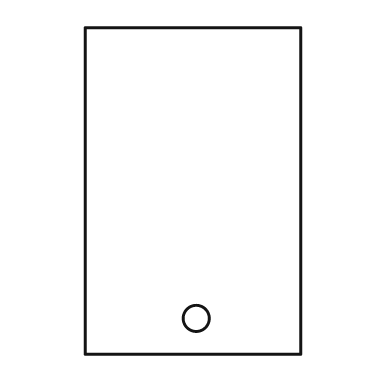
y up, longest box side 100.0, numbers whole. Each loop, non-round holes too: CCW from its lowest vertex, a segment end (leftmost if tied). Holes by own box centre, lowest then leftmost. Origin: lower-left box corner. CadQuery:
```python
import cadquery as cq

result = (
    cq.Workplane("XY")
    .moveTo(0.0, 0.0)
    .lineTo(66.0, 0.0)
    .lineTo(66.0, 100.0)
    .lineTo(0.0, 100.0)
    .close()
    .moveTo(34.0, 11.0)
    .circle(4.0)
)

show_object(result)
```